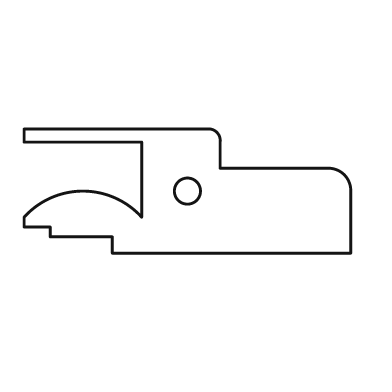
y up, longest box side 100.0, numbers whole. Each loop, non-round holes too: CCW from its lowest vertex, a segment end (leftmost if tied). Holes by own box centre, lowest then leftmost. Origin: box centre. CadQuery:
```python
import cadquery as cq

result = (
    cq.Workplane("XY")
    .moveTo(-23.0, -19.0)
    .lineTo(50.0, -19.0)
    .lineTo(50.0, 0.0)
    .threePointArc((48.0, 5.0), (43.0, 7.0))
    .lineTo(10.0, 7.0)
    .lineTo(10.0, 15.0)
    .threePointArc((9.0, 18.0), (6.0, 19.0))
    .lineTo(-50.0, 19.0)
    .lineTo(-50.0, 15.0)
    .lineTo(-14.0, 15.0)
    .lineTo(-14.0, -8.0)
    .threePointArc((-32.0, 0.0), (-50.0, -8.0))
    .lineTo(-50.0, -11.0)
    .lineTo(-42.0, -11.0)
    .lineTo(-42.0, -14.0)
    .lineTo(-23.0, -14.0)
    .close()
    .moveTo(0.0, 0.0)
    .circle(4.0)
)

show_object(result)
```